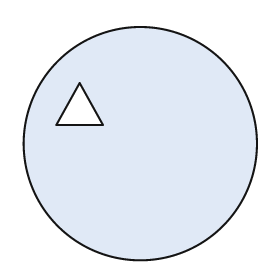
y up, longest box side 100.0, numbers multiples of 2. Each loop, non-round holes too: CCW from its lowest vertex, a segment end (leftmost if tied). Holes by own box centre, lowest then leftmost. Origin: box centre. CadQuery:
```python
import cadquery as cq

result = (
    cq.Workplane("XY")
    .moveTo(0.0, 0.0)
    .circle(50.0)
    .moveTo(-36.0, 8.0)
    .lineTo(-16.0, 8.0)
    .lineTo(-26.0, 26.0)
    .close()
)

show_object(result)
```